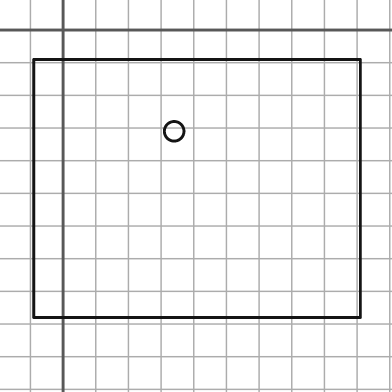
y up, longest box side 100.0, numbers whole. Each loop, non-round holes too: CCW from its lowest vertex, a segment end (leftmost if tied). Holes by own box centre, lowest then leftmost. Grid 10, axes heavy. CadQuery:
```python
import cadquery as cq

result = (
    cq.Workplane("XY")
    .moveTo(-9.0, -88.0)
    .lineTo(91.0, -88.0)
    .lineTo(91.0, -9.0)
    .lineTo(-9.0, -9.0)
    .close()
    .moveTo(34.0, -31.0)
    .circle(3.0)
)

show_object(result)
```